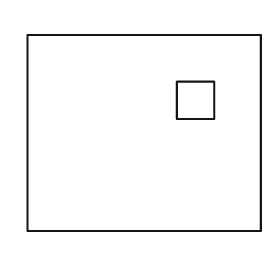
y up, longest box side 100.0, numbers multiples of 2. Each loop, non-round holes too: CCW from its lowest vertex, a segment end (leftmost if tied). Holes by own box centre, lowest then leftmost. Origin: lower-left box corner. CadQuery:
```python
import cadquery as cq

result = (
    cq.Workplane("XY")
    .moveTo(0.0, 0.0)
    .lineTo(100.0, 0.0)
    .lineTo(100.0, 84.0)
    .lineTo(0.0, 84.0)
    .close()
    .moveTo(64.0, 48.0)
    .lineTo(80.0, 48.0)
    .lineTo(80.0, 64.0)
    .lineTo(64.0, 64.0)
    .close()
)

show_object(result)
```